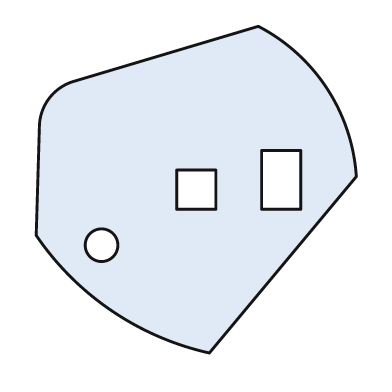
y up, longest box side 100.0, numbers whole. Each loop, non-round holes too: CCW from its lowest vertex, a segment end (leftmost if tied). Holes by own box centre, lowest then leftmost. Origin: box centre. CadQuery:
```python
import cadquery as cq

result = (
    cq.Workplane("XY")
    .moveTo(4.0, -50.0)
    .lineTo(49.0, 4.0)
    .threePointArc((40.0, 31.0), (19.0, 50.0))
    .lineTo(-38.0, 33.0)
    .threePointArc((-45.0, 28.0), (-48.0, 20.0))
    .lineTo(-49.0, -14.0)
    .threePointArc((-26.0, -37.0), (4.0, -50.0))
    .close()
    .moveTo(-29.0, -17.0)
    .circle(5.0)
    .moveTo(-6.0, -6.0)
    .lineTo(6.0, -6.0)
    .lineTo(6.0, 6.0)
    .lineTo(-6.0, 6.0)
    .close()
    .moveTo(20.0, -6.0)
    .lineTo(32.0, -6.0)
    .lineTo(32.0, 12.0)
    .lineTo(20.0, 12.0)
    .close()
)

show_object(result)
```